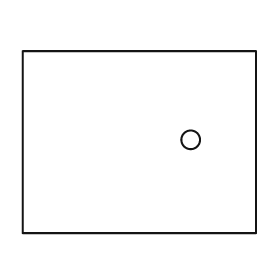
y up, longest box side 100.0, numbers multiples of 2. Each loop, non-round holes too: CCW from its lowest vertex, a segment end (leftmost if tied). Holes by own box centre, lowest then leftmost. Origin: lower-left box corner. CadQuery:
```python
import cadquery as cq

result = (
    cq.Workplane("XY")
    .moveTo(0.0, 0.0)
    .lineTo(100.0, 0.0)
    .lineTo(100.0, 78.0)
    .lineTo(0.0, 78.0)
    .close()
    .moveTo(72.0, 40.0)
    .circle(4.0)
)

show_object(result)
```